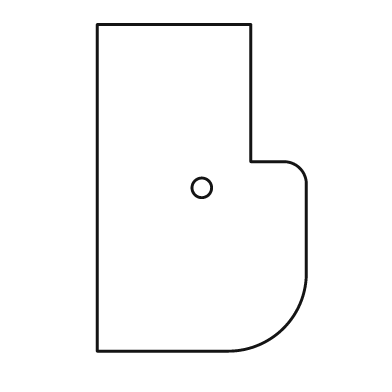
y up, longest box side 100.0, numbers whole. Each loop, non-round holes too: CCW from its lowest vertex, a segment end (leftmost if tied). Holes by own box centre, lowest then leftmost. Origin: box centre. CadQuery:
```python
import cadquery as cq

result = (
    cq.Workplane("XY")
    .moveTo(-32.0, -50.0)
    .lineTo(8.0, -50.0)
    .threePointArc((25.0, -43.0), (32.0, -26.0))
    .lineTo(32.0, 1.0)
    .threePointArc((30.0, 6.0), (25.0, 8.0))
    .lineTo(15.0, 8.0)
    .lineTo(15.0, 50.0)
    .lineTo(-32.0, 50.0)
    .close()
    .moveTo(0.0, 0.0)
    .circle(3.0)
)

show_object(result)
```